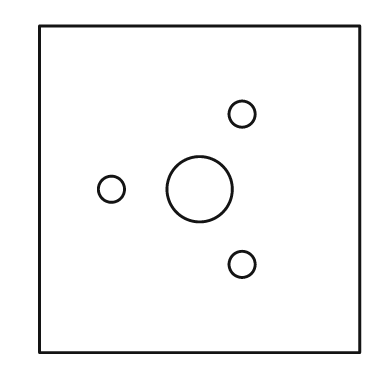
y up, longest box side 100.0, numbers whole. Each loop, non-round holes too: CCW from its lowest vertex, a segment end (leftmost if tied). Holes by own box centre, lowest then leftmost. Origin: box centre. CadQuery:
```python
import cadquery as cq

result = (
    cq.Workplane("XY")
    .moveTo(-49.0, -50.0)
    .lineTo(49.0, -50.0)
    .lineTo(49.0, 50.0)
    .lineTo(-49.0, 50.0)
    .close()
    .moveTo(13.0, -23.0)
    .circle(4.0)
    .moveTo(-27.0, 0.0)
    .circle(4.0)
    .moveTo(0.0, 0.0)
    .circle(10.0)
    .moveTo(13.0, 23.0)
    .circle(4.0)
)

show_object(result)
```